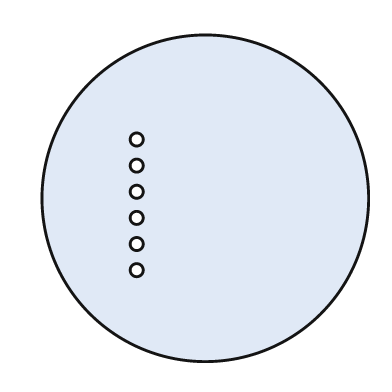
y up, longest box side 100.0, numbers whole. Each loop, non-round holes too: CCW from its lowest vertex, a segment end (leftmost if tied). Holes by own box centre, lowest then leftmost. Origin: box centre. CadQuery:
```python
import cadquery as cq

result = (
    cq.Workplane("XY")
    .moveTo(0.0, 0.0)
    .circle(50.0)
    .moveTo(-21.0, -22.0)
    .circle(2.0)
    .moveTo(-21.0, -14.0)
    .circle(2.0)
    .moveTo(-21.0, -6.0)
    .circle(2.0)
    .moveTo(-21.0, 2.0)
    .circle(2.0)
    .moveTo(-21.0, 10.0)
    .circle(2.0)
    .moveTo(-21.0, 18.0)
    .circle(2.0)
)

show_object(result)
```